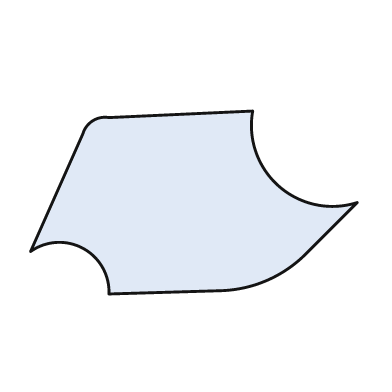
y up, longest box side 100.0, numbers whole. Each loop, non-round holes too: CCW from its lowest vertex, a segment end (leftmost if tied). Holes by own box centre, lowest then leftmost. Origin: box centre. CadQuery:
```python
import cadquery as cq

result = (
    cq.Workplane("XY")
    .moveTo(-26.0, -28.0)
    .lineTo(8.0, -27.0)
    .threePointArc((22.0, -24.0), (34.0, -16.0))
    .lineTo(50.0, 0.0)
    .threePointArc((26.0, 5.0), (18.0, 28.0))
    .lineTo(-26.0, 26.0)
    .threePointArc((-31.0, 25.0), (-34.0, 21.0))
    .lineTo(-50.0, -15.0)
    .threePointArc((-34.0, -14.0), (-26.0, -28.0))
    .close()
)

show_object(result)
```